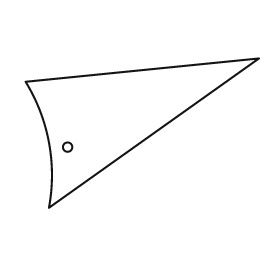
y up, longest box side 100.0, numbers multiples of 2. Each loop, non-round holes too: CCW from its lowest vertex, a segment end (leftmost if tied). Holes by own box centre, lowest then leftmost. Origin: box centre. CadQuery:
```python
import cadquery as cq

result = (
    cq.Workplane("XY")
    .moveTo(-40.0, -32.0)
    .lineTo(50.0, 32.0)
    .lineTo(-50.0, 22.0)
    .threePointArc((-40.0, -4.0), (-40.0, -32.0))
    .close()
    .moveTo(-32.0, -6.0)
    .circle(2.0)
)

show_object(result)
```